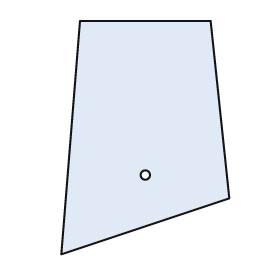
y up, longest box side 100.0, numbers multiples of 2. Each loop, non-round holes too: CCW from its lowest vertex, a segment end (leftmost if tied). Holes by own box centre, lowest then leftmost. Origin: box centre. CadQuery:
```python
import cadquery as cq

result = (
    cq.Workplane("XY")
    .moveTo(-36.0, -50.0)
    .lineTo(36.0, -26.0)
    .lineTo(28.0, 50.0)
    .lineTo(-28.0, 50.0)
    .close()
    .moveTo(0.0, -16.0)
    .circle(2.0)
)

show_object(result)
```